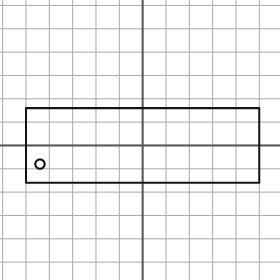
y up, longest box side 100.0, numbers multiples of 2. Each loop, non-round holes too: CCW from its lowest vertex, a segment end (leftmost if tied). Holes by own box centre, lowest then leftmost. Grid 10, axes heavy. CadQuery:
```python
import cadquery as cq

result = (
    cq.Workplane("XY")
    .moveTo(-50.0, -16.0)
    .lineTo(50.0, -16.0)
    .lineTo(50.0, 16.0)
    .lineTo(-50.0, 16.0)
    .close()
    .moveTo(-44.0, -8.0)
    .circle(2.0)
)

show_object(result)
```